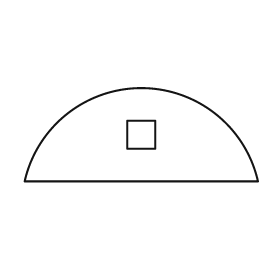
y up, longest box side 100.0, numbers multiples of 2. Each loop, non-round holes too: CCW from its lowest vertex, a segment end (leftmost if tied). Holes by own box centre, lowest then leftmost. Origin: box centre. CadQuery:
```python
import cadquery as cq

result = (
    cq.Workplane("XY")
    .moveTo(-50.0, -20.0)
    .lineTo(50.0, -20.0)
    .threePointArc((0.0, 20.0), (-50.0, -20.0))
    .close()
    .moveTo(-6.0, -6.0)
    .lineTo(6.0, -6.0)
    .lineTo(6.0, 6.0)
    .lineTo(-6.0, 6.0)
    .close()
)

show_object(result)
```